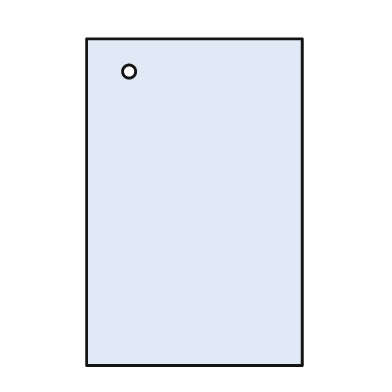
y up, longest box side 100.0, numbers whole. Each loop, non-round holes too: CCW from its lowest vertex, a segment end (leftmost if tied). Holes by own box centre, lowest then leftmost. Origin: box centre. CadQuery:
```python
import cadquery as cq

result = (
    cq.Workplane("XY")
    .moveTo(-33.0, -50.0)
    .lineTo(33.0, -50.0)
    .lineTo(33.0, 50.0)
    .lineTo(-33.0, 50.0)
    .close()
    .moveTo(-20.0, 40.0)
    .circle(2.0)
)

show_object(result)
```